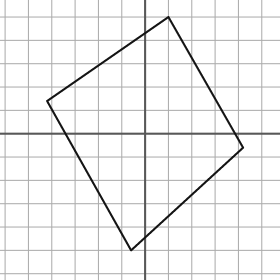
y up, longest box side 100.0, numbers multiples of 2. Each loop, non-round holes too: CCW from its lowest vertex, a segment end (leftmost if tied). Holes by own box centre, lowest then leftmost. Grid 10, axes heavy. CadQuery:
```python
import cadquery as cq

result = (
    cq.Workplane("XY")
    .moveTo(-6.0, -50.0)
    .lineTo(42.0, -6.0)
    .lineTo(10.0, 50.0)
    .lineTo(-42.0, 14.0)
    .close()
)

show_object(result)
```